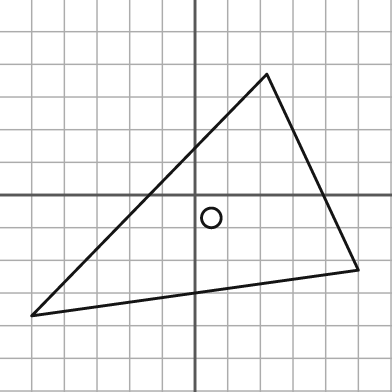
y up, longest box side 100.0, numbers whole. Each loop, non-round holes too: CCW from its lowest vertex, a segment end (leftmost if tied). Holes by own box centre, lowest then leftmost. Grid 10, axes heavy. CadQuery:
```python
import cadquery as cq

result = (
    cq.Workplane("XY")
    .moveTo(-50.0, -37.0)
    .lineTo(50.0, -23.0)
    .lineTo(22.0, 37.0)
    .close()
    .moveTo(5.0, -7.0)
    .circle(3.0)
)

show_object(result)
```